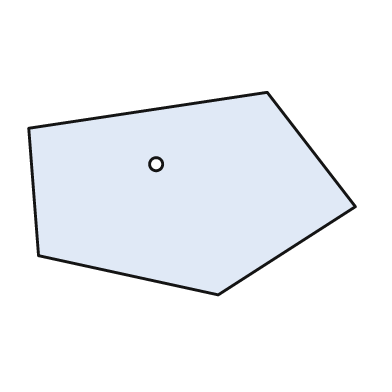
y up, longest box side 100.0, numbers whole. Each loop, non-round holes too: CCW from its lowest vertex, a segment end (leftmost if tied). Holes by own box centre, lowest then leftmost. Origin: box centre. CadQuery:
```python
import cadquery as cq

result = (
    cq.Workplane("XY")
    .moveTo(8.0, -31.0)
    .lineTo(50.0, -4.0)
    .lineTo(23.0, 31.0)
    .lineTo(-50.0, 20.0)
    .lineTo(-47.0, -19.0)
    .close()
    .moveTo(-11.0, 9.0)
    .circle(2.0)
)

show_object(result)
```